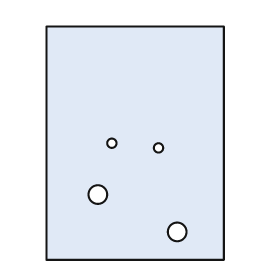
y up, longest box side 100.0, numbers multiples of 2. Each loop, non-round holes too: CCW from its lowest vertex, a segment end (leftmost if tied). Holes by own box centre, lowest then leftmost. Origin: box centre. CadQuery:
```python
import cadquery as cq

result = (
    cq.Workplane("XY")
    .moveTo(-38.0, -50.0)
    .lineTo(38.0, -50.0)
    .lineTo(38.0, 50.0)
    .lineTo(-38.0, 50.0)
    .close()
    .moveTo(18.0, -38.0)
    .circle(4.0)
    .moveTo(-16.0, -22.0)
    .circle(4.0)
    .moveTo(10.0, -2.0)
    .circle(2.0)
    .moveTo(-10.0, 0.0)
    .circle(2.0)
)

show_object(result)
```